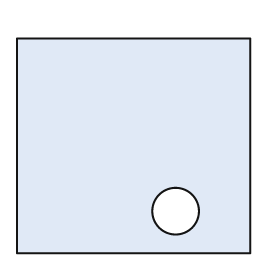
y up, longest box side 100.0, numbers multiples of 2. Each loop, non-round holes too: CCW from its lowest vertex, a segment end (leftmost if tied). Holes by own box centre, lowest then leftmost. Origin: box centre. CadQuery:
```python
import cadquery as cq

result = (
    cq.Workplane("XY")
    .moveTo(-50.0, -46.0)
    .lineTo(50.0, -46.0)
    .lineTo(50.0, 46.0)
    .lineTo(-50.0, 46.0)
    .close()
    .moveTo(18.0, -28.0)
    .circle(10.0)
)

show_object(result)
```